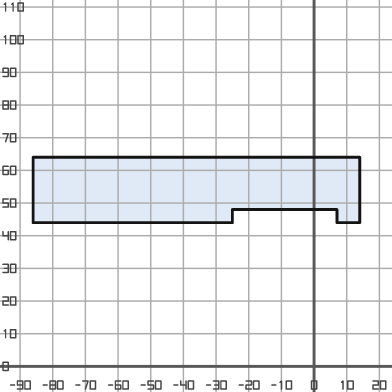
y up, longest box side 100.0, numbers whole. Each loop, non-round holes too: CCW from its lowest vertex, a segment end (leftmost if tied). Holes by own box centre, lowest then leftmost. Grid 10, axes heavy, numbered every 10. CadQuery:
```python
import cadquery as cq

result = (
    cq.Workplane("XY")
    .moveTo(-86.0, 44.0)
    .lineTo(-25.0, 44.0)
    .lineTo(-25.0, 48.0)
    .lineTo(7.0, 48.0)
    .lineTo(7.0, 44.0)
    .lineTo(14.0, 44.0)
    .lineTo(14.0, 64.0)
    .lineTo(-86.0, 64.0)
    .close()
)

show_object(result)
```